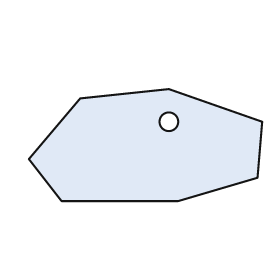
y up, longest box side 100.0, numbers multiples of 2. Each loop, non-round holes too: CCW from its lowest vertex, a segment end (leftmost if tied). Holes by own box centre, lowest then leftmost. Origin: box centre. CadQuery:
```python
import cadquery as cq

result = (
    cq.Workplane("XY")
    .moveTo(-36.0, -24.0)
    .lineTo(14.0, -24.0)
    .lineTo(48.0, -14.0)
    .lineTo(50.0, 10.0)
    .lineTo(10.0, 24.0)
    .lineTo(-28.0, 20.0)
    .lineTo(-50.0, -6.0)
    .close()
    .moveTo(10.0, 10.0)
    .circle(4.0)
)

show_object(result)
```